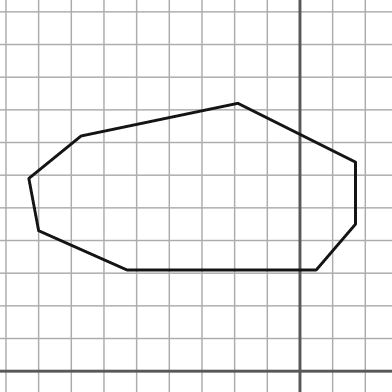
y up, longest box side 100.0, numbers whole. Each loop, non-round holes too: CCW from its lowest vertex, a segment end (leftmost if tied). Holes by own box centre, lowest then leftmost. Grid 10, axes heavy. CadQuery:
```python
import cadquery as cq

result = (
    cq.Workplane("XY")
    .moveTo(-53.0, 31.0)
    .lineTo(5.0, 31.0)
    .lineTo(17.0, 45.0)
    .lineTo(17.0, 64.0)
    .lineTo(-19.0, 82.0)
    .lineTo(-67.0, 72.0)
    .lineTo(-83.0, 59.0)
    .lineTo(-80.0, 43.0)
    .close()
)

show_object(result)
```